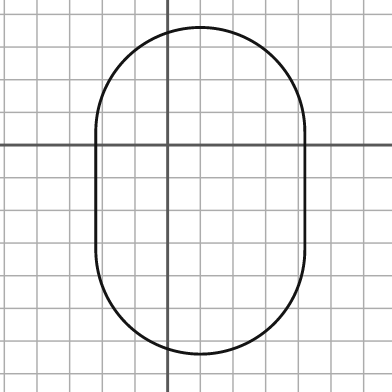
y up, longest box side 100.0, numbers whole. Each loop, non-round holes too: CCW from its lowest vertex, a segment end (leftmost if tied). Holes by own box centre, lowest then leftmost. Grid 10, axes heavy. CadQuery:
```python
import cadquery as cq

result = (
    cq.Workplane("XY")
    .moveTo(-22.0, -32.0)
    .threePointArc((10.0, -64.0), (42.0, -32.0))
    .lineTo(42.0, 4.0)
    .threePointArc((10.0, 36.0), (-22.0, 4.0))
    .close()
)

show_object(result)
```